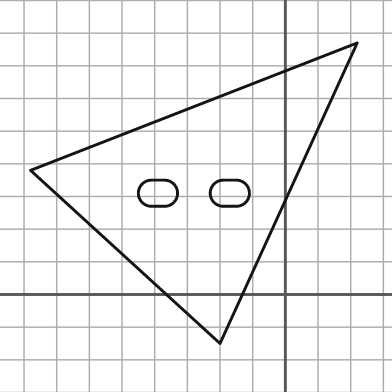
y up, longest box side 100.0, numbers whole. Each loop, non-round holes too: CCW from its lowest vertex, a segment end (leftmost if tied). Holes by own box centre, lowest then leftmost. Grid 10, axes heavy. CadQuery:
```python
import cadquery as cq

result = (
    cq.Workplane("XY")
    .moveTo(-20.0, -15.0)
    .lineTo(22.0, 77.0)
    .lineTo(-78.0, 38.0)
    .close()
    .moveTo(-41.0, 27.0)
    .lineTo(-37.0, 27.0)
    .threePointArc((-33.0, 31.0), (-37.0, 35.0))
    .lineTo(-41.0, 35.0)
    .threePointArc((-45.0, 31.0), (-41.0, 27.0))
    .close()
    .moveTo(-19.0, 27.0)
    .lineTo(-15.0, 27.0)
    .threePointArc((-11.0, 31.0), (-15.0, 35.0))
    .lineTo(-19.0, 35.0)
    .threePointArc((-23.0, 31.0), (-19.0, 27.0))
    .close()
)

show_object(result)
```